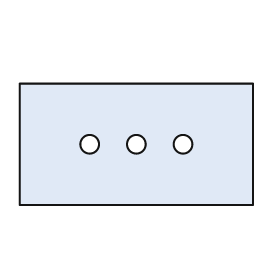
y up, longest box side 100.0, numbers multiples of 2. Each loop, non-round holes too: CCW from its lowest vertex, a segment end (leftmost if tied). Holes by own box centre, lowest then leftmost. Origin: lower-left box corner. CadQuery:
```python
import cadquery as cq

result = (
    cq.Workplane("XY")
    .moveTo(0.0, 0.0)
    .lineTo(100.0, 0.0)
    .lineTo(100.0, 52.0)
    .lineTo(0.0, 52.0)
    .close()
    .moveTo(30.0, 26.0)
    .circle(4.0)
    .moveTo(50.0, 26.0)
    .circle(4.0)
    .moveTo(70.0, 26.0)
    .circle(4.0)
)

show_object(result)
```